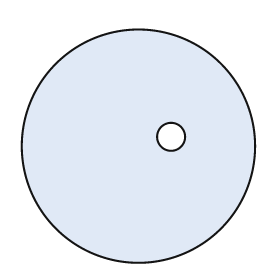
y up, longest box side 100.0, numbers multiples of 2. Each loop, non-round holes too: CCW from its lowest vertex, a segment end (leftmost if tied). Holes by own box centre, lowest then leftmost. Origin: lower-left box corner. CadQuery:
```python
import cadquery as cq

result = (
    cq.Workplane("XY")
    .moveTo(50.0, 50.0)
    .circle(50.0)
    .moveTo(64.0, 54.0)
    .circle(6.0)
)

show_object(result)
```